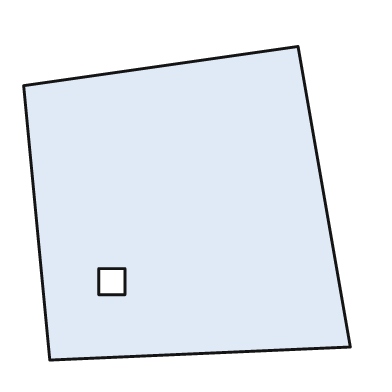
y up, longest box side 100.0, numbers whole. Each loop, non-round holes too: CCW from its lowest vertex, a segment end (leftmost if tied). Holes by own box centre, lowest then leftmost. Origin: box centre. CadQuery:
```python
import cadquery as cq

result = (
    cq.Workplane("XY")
    .moveTo(-42.0, -48.0)
    .lineTo(50.0, -44.0)
    .lineTo(34.0, 48.0)
    .lineTo(-50.0, 36.0)
    .close()
    .moveTo(-27.0, -28.0)
    .lineTo(-19.0, -28.0)
    .lineTo(-19.0, -20.0)
    .lineTo(-27.0, -20.0)
    .close()
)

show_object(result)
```